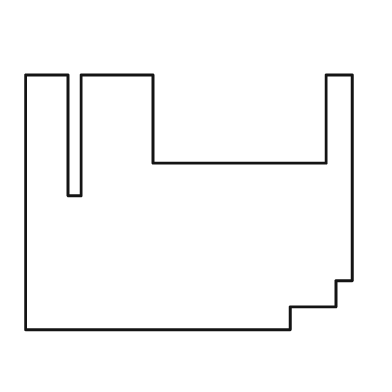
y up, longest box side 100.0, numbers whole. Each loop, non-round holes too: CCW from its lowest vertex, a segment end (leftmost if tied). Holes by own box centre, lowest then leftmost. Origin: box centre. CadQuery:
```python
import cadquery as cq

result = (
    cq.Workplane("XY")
    .moveTo(-50.0, -39.0)
    .lineTo(31.0, -39.0)
    .lineTo(31.0, -32.0)
    .lineTo(45.0, -32.0)
    .lineTo(45.0, -24.0)
    .lineTo(50.0, -24.0)
    .lineTo(50.0, 39.0)
    .lineTo(42.0, 39.0)
    .lineTo(42.0, 12.0)
    .lineTo(-11.0, 12.0)
    .lineTo(-11.0, 39.0)
    .lineTo(-33.0, 39.0)
    .lineTo(-33.0, 2.0)
    .lineTo(-37.0, 2.0)
    .lineTo(-37.0, 39.0)
    .lineTo(-50.0, 39.0)
    .close()
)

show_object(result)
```